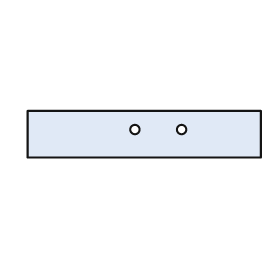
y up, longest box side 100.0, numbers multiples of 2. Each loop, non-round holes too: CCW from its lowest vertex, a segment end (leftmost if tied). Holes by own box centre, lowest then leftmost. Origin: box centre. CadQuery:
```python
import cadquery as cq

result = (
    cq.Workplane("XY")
    .moveTo(-50.0, -10.0)
    .lineTo(50.0, -10.0)
    .lineTo(50.0, 10.0)
    .lineTo(-50.0, 10.0)
    .close()
    .moveTo(-4.0, 2.0)
    .circle(2.0)
    .moveTo(16.0, 2.0)
    .circle(2.0)
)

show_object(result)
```